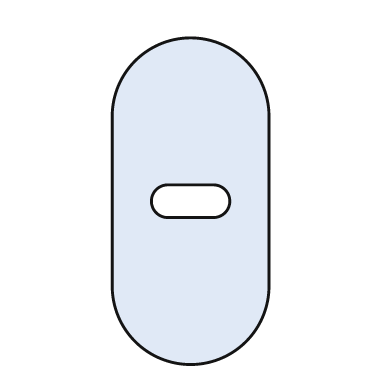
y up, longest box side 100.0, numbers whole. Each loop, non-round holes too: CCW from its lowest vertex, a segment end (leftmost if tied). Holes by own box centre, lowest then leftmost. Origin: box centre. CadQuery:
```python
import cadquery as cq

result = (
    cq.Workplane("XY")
    .moveTo(-24.0, -26.0)
    .threePointArc((0.0, -50.0), (24.0, -26.0))
    .lineTo(24.0, 26.0)
    .threePointArc((0.0, 50.0), (-24.0, 26.0))
    .close()
    .moveTo(-7.0, -5.0)
    .lineTo(7.0, -5.0)
    .threePointArc((12.0, 0.0), (7.0, 5.0))
    .lineTo(-7.0, 5.0)
    .threePointArc((-12.0, 0.0), (-7.0, -5.0))
    .close()
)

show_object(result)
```